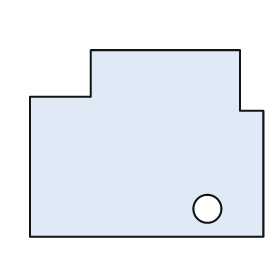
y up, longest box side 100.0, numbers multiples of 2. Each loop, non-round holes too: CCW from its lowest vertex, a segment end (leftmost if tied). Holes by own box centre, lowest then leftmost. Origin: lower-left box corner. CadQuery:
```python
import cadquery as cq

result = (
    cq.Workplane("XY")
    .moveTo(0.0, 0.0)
    .lineTo(100.0, 0.0)
    .lineTo(100.0, 54.0)
    .lineTo(90.0, 54.0)
    .lineTo(90.0, 80.0)
    .lineTo(26.0, 80.0)
    .lineTo(26.0, 60.0)
    .lineTo(0.0, 60.0)
    .close()
    .moveTo(76.0, 12.0)
    .circle(6.0)
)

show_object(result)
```